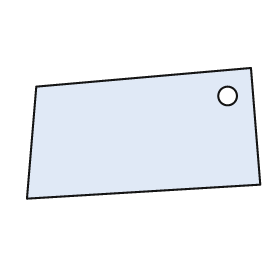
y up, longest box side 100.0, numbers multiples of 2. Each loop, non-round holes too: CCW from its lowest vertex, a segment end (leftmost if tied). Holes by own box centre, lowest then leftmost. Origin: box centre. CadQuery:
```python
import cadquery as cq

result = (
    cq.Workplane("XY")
    .moveTo(-50.0, -28.0)
    .lineTo(50.0, -22.0)
    .lineTo(46.0, 28.0)
    .lineTo(-46.0, 20.0)
    .close()
    .moveTo(36.0, 16.0)
    .circle(4.0)
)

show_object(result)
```